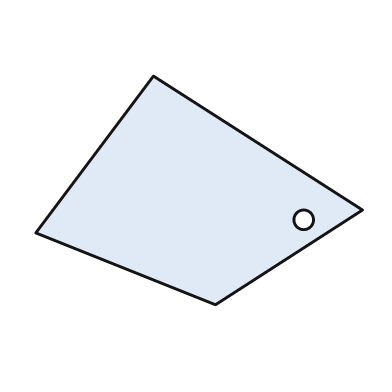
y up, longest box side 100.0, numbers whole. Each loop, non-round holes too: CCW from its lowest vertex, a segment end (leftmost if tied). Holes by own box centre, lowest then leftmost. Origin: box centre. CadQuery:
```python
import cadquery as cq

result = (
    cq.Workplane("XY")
    .moveTo(5.0, -35.0)
    .lineTo(50.0, -6.0)
    .lineTo(-14.0, 35.0)
    .lineTo(-50.0, -13.0)
    .close()
    .moveTo(32.0, -9.0)
    .circle(3.0)
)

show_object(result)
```